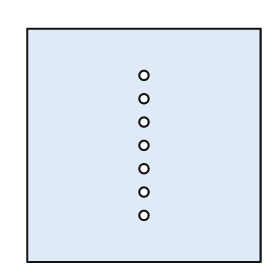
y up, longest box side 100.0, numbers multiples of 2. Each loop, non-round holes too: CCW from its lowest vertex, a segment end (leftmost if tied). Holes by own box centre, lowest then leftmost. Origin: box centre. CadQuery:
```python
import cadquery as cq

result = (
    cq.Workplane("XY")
    .moveTo(-50.0, -50.0)
    .lineTo(50.0, -50.0)
    .lineTo(50.0, 50.0)
    .lineTo(-50.0, 50.0)
    .close()
    .moveTo(0.0, -30.0)
    .circle(2.0)
    .moveTo(0.0, -20.0)
    .circle(2.0)
    .moveTo(0.0, -10.0)
    .circle(2.0)
    .moveTo(0.0, 0.0)
    .circle(2.0)
    .moveTo(0.0, 10.0)
    .circle(2.0)
    .moveTo(0.0, 20.0)
    .circle(2.0)
    .moveTo(0.0, 30.0)
    .circle(2.0)
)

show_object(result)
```